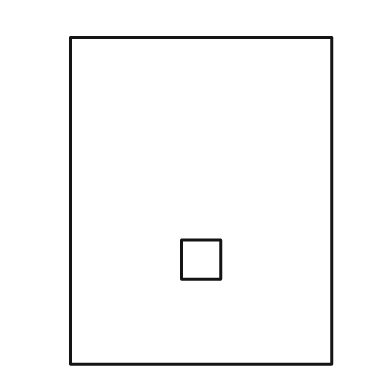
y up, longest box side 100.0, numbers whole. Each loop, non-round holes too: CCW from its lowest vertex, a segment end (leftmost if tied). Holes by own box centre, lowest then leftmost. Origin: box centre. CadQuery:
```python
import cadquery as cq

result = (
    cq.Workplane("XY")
    .moveTo(-40.0, -50.0)
    .lineTo(40.0, -50.0)
    .lineTo(40.0, 50.0)
    .lineTo(-40.0, 50.0)
    .close()
    .moveTo(-6.0, -24.0)
    .lineTo(6.0, -24.0)
    .lineTo(6.0, -12.0)
    .lineTo(-6.0, -12.0)
    .close()
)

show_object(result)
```